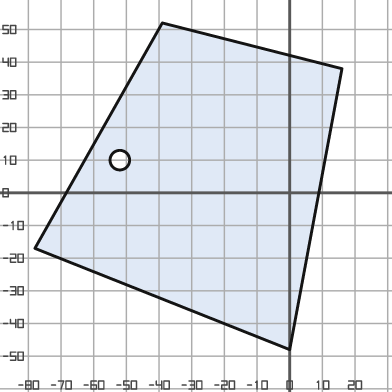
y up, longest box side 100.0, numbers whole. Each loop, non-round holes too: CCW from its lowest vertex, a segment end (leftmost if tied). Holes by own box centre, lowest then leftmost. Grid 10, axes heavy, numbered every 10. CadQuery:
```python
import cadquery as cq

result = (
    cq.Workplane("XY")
    .moveTo(0.0, -48.0)
    .lineTo(16.0, 38.0)
    .lineTo(-39.0, 52.0)
    .lineTo(-78.0, -17.0)
    .close()
    .moveTo(-52.0, 10.0)
    .circle(3.0)
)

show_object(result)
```